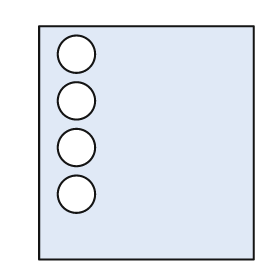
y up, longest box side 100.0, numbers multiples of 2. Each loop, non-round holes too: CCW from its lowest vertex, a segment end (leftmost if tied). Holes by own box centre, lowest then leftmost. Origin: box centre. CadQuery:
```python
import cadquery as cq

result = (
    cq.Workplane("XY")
    .moveTo(-46.0, -50.0)
    .lineTo(46.0, -50.0)
    .lineTo(46.0, 50.0)
    .lineTo(-46.0, 50.0)
    .close()
    .moveTo(-30.0, -22.0)
    .circle(8.0)
    .moveTo(-30.0, -2.0)
    .circle(8.0)
    .moveTo(-30.0, 18.0)
    .circle(8.0)
    .moveTo(-30.0, 38.0)
    .circle(8.0)
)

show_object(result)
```